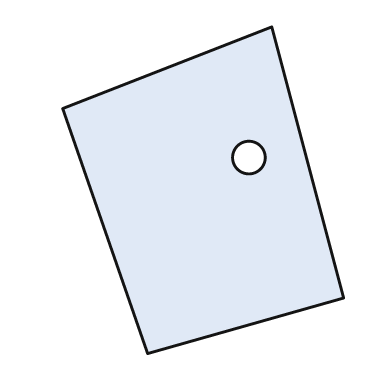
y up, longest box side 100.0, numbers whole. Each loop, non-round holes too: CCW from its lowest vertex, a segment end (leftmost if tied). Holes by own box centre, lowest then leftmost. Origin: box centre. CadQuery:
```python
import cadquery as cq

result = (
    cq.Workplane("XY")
    .moveTo(-17.0, -50.0)
    .lineTo(43.0, -33.0)
    .lineTo(21.0, 50.0)
    .lineTo(-43.0, 25.0)
    .close()
    .moveTo(14.0, 10.0)
    .circle(5.0)
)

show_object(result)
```